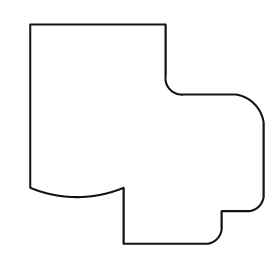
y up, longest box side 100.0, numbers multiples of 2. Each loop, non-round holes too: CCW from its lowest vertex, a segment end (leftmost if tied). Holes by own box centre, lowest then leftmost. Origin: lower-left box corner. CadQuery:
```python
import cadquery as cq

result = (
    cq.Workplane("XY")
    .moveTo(40.0, 0.0)
    .lineTo(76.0, 0.0)
    .threePointArc((80.0, 2.0), (82.0, 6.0))
    .lineTo(82.0, 14.0)
    .lineTo(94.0, 14.0)
    .threePointArc((98.0, 16.0), (100.0, 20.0))
    .lineTo(100.0, 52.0)
    .threePointArc((96.0, 60.0), (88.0, 64.0))
    .lineTo(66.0, 64.0)
    .threePointArc((60.0, 66.0), (58.0, 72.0))
    .lineTo(58.0, 94.0)
    .lineTo(0.0, 94.0)
    .lineTo(0.0, 24.0)
    .threePointArc((20.0, 20.0), (40.0, 24.0))
    .close()
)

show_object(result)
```